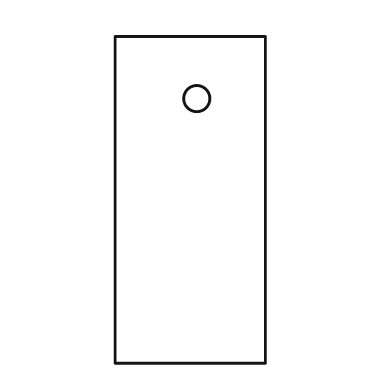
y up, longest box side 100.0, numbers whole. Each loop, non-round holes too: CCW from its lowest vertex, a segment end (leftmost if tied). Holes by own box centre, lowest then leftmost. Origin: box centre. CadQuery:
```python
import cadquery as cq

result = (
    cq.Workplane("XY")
    .moveTo(-23.0, -50.0)
    .lineTo(23.0, -50.0)
    .lineTo(23.0, 50.0)
    .lineTo(-23.0, 50.0)
    .close()
    .moveTo(2.0, 31.0)
    .circle(4.0)
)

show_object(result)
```